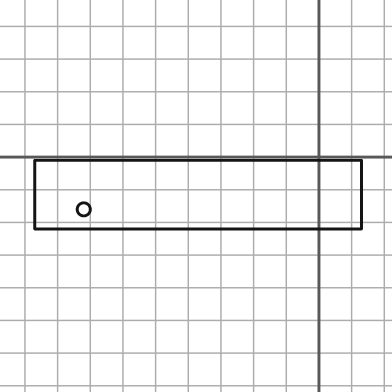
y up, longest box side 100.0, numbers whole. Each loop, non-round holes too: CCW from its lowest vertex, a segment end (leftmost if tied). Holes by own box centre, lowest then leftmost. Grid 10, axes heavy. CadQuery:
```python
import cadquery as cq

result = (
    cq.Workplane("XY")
    .moveTo(-87.0, -22.0)
    .lineTo(13.0, -22.0)
    .lineTo(13.0, -1.0)
    .lineTo(-87.0, -1.0)
    .close()
    .moveTo(-72.0, -16.0)
    .circle(2.0)
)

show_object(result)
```